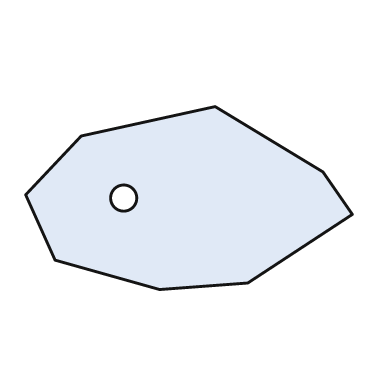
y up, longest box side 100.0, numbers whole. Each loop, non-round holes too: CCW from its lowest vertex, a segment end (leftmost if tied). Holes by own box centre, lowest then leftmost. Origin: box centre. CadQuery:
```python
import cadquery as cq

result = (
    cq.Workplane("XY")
    .moveTo(-9.0, -28.0)
    .lineTo(18.0, -26.0)
    .lineTo(50.0, -5.0)
    .lineTo(41.0, 8.0)
    .lineTo(8.0, 28.0)
    .lineTo(-33.0, 19.0)
    .lineTo(-50.0, 1.0)
    .lineTo(-41.0, -19.0)
    .close()
    .moveTo(-20.0, 0.0)
    .circle(4.0)
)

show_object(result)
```